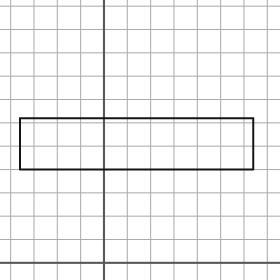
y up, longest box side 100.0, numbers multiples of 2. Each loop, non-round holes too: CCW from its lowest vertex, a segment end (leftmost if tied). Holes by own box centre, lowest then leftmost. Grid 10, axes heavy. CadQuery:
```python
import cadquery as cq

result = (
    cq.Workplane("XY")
    .moveTo(-36.0, 40.0)
    .lineTo(64.0, 40.0)
    .lineTo(64.0, 62.0)
    .lineTo(-36.0, 62.0)
    .close()
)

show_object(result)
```